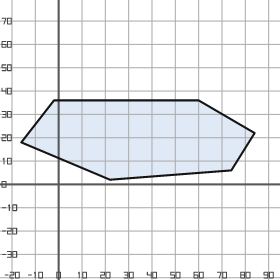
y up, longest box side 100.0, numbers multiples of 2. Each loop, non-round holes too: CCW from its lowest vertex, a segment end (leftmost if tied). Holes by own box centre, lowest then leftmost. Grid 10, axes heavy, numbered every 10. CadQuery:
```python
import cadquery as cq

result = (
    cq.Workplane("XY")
    .moveTo(22.0, 2.0)
    .lineTo(74.0, 6.0)
    .lineTo(84.0, 22.0)
    .lineTo(60.0, 36.0)
    .lineTo(-2.0, 36.0)
    .lineTo(-16.0, 18.0)
    .close()
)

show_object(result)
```